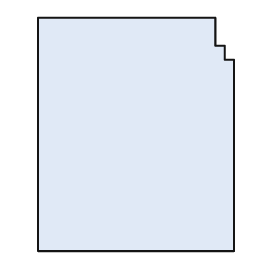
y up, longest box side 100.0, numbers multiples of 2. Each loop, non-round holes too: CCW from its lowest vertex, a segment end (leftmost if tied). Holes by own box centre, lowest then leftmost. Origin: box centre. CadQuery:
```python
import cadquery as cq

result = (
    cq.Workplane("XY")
    .moveTo(-42.0, -50.0)
    .lineTo(42.0, -50.0)
    .lineTo(42.0, 32.0)
    .lineTo(38.0, 32.0)
    .lineTo(38.0, 38.0)
    .lineTo(34.0, 38.0)
    .lineTo(34.0, 50.0)
    .lineTo(-42.0, 50.0)
    .close()
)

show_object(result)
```